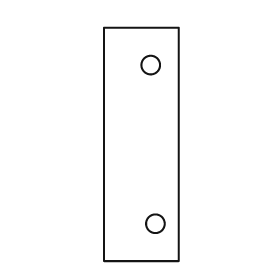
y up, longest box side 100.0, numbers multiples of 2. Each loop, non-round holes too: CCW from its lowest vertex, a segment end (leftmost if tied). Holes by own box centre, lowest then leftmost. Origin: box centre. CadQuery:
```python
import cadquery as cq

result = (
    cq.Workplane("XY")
    .moveTo(-16.0, -50.0)
    .lineTo(16.0, -50.0)
    .lineTo(16.0, 50.0)
    .lineTo(-16.0, 50.0)
    .close()
    .moveTo(6.0, -34.0)
    .circle(4.0)
    .moveTo(4.0, 34.0)
    .circle(4.0)
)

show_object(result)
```